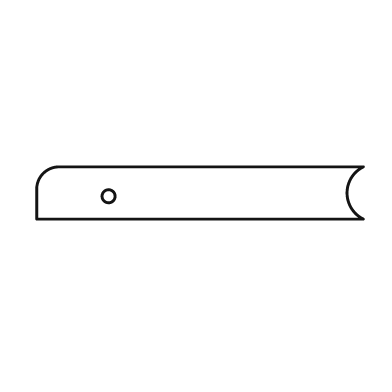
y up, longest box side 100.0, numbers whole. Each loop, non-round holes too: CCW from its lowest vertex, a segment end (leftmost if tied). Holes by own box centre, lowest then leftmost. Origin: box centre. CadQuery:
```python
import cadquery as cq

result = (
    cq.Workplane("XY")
    .moveTo(-50.0, -8.0)
    .lineTo(50.0, -8.0)
    .threePointArc((45.0, 0.0), (50.0, 8.0))
    .lineTo(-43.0, 8.0)
    .threePointArc((-48.0, 6.0), (-50.0, 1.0))
    .close()
    .moveTo(-28.0, -1.0)
    .circle(2.0)
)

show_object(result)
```